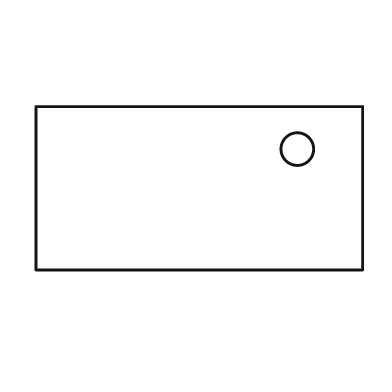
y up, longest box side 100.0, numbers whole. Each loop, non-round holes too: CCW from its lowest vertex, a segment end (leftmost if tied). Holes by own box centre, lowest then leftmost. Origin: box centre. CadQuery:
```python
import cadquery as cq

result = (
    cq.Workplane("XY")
    .moveTo(-50.0, -25.0)
    .lineTo(50.0, -25.0)
    .lineTo(50.0, 25.0)
    .lineTo(-50.0, 25.0)
    .close()
    .moveTo(30.0, 12.0)
    .circle(5.0)
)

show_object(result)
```